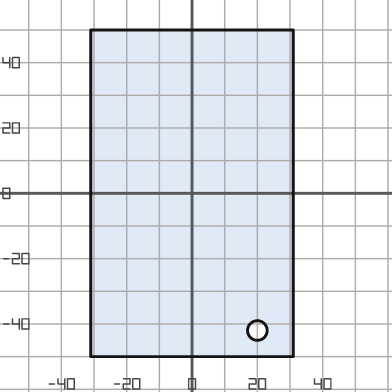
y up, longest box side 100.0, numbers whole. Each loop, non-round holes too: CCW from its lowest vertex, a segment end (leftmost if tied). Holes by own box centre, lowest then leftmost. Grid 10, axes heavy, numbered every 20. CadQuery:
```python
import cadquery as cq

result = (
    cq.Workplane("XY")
    .moveTo(-31.0, -50.0)
    .lineTo(31.0, -50.0)
    .lineTo(31.0, 50.0)
    .lineTo(-31.0, 50.0)
    .close()
    .moveTo(20.0, -42.0)
    .circle(3.0)
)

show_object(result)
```